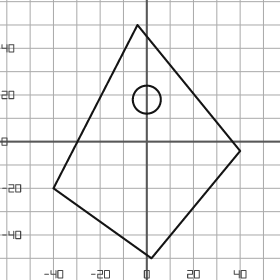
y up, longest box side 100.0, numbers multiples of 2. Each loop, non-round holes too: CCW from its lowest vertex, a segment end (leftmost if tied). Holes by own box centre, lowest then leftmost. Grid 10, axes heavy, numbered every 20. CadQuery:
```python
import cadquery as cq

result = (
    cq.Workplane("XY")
    .moveTo(2.0, -50.0)
    .lineTo(40.0, -4.0)
    .lineTo(-4.0, 50.0)
    .lineTo(-40.0, -20.0)
    .close()
    .moveTo(0.0, 18.0)
    .circle(6.0)
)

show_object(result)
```